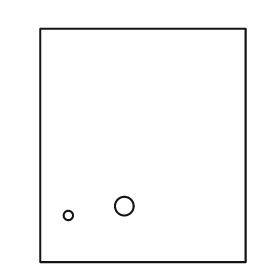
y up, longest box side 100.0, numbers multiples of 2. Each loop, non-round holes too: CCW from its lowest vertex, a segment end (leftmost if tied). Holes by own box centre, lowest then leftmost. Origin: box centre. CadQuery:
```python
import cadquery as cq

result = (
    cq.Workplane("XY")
    .moveTo(-44.0, -50.0)
    .lineTo(44.0, -50.0)
    .lineTo(44.0, 50.0)
    .lineTo(-44.0, 50.0)
    .close()
    .moveTo(-32.0, -30.0)
    .circle(2.0)
    .moveTo(-8.0, -26.0)
    .circle(4.0)
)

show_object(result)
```